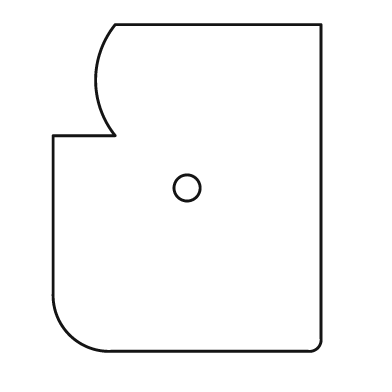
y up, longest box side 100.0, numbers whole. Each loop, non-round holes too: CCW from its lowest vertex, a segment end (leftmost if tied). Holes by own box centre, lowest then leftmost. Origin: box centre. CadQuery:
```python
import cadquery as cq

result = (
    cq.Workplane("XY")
    .moveTo(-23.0, -50.0)
    .lineTo(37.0, -50.0)
    .threePointArc((40.0, -49.0), (41.0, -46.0))
    .lineTo(41.0, 50.0)
    .lineTo(-22.0, 50.0)
    .threePointArc((-28.0, 33.0), (-22.0, 16.0))
    .lineTo(-41.0, 16.0)
    .lineTo(-41.0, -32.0)
    .threePointArc((-36.0, -45.0), (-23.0, -50.0))
    .close()
    .moveTo(0.0, 0.0)
    .circle(4.0)
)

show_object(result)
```